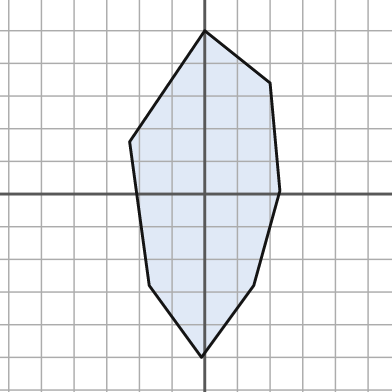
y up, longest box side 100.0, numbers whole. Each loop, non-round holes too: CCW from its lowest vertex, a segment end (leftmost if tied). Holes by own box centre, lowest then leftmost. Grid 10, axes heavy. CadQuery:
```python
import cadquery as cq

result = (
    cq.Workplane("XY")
    .moveTo(-1.0, -50.0)
    .lineTo(15.0, -28.0)
    .lineTo(23.0, 1.0)
    .lineTo(20.0, 34.0)
    .lineTo(0.0, 50.0)
    .lineTo(-23.0, 16.0)
    .lineTo(-17.0, -28.0)
    .close()
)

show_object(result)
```